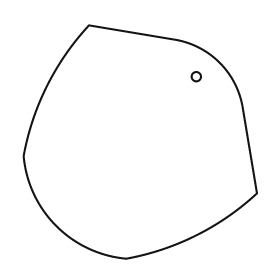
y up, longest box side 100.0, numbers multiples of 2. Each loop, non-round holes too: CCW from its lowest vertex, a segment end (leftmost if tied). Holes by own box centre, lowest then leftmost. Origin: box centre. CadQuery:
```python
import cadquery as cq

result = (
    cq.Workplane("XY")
    .moveTo(-6.0, -50.0)
    .threePointArc((24.0, -40.0), (50.0, -22.0))
    .lineTo(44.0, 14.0)
    .threePointArc((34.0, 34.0), (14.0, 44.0))
    .lineTo(-22.0, 50.0)
    .threePointArc((-40.0, 24.0), (-50.0, -6.0))
    .threePointArc((-36.0, -36.0), (-6.0, -50.0))
    .close()
    .moveTo(24.0, 28.0)
    .circle(2.0)
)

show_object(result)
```